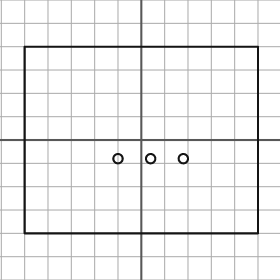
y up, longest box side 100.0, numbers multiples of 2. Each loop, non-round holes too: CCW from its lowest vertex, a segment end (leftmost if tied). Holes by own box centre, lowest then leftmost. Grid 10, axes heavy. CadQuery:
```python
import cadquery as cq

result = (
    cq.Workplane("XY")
    .moveTo(-50.0, -40.0)
    .lineTo(50.0, -40.0)
    .lineTo(50.0, 40.0)
    .lineTo(-50.0, 40.0)
    .close()
    .moveTo(-10.0, -8.0)
    .circle(2.0)
    .moveTo(4.0, -8.0)
    .circle(2.0)
    .moveTo(18.0, -8.0)
    .circle(2.0)
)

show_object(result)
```